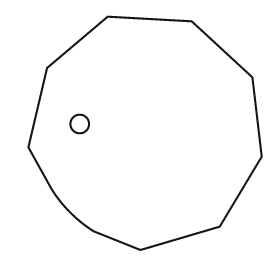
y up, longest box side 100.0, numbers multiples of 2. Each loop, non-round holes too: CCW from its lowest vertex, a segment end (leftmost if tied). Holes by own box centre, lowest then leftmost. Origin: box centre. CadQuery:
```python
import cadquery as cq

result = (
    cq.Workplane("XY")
    .moveTo(-2.0, -50.0)
    .lineTo(32.0, -40.0)
    .lineTo(50.0, -10.0)
    .lineTo(46.0, 24.0)
    .lineTo(20.0, 48.0)
    .lineTo(-16.0, 50.0)
    .lineTo(-42.0, 28.0)
    .lineTo(-50.0, -6.0)
    .lineTo(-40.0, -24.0)
    .threePointArc((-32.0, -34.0), (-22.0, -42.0))
    .close()
    .moveTo(-28.0, 4.0)
    .circle(4.0)
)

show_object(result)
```